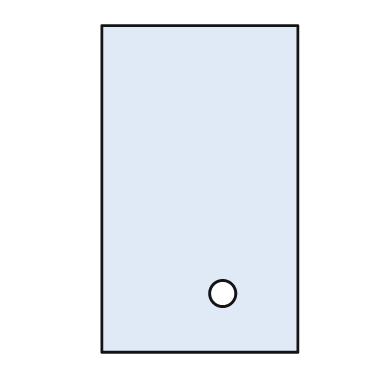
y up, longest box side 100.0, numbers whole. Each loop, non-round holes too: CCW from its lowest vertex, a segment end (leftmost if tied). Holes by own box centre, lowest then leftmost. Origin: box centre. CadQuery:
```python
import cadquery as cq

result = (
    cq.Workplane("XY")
    .moveTo(-30.0, -50.0)
    .lineTo(30.0, -50.0)
    .lineTo(30.0, 50.0)
    .lineTo(-30.0, 50.0)
    .close()
    .moveTo(7.0, -32.0)
    .circle(4.0)
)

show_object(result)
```